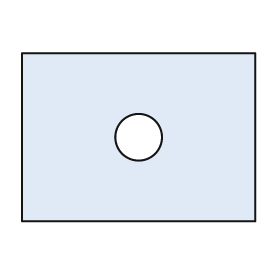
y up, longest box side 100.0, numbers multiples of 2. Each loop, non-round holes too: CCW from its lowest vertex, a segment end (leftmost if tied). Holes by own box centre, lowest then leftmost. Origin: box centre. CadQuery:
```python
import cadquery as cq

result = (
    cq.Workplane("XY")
    .moveTo(-50.0, -36.0)
    .lineTo(50.0, -36.0)
    .lineTo(50.0, 36.0)
    .lineTo(-50.0, 36.0)
    .close()
    .moveTo(0.0, 0.0)
    .circle(10.0)
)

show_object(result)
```